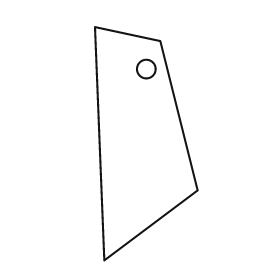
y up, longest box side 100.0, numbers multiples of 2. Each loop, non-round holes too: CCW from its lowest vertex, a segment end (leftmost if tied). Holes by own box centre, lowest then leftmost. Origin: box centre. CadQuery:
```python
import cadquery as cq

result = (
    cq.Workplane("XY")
    .moveTo(-18.0, -50.0)
    .lineTo(22.0, -20.0)
    .lineTo(6.0, 44.0)
    .lineTo(-22.0, 50.0)
    .close()
    .moveTo(0.0, 32.0)
    .circle(4.0)
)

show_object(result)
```